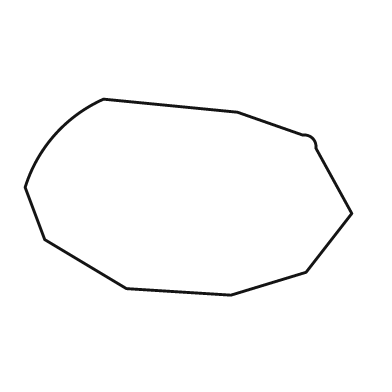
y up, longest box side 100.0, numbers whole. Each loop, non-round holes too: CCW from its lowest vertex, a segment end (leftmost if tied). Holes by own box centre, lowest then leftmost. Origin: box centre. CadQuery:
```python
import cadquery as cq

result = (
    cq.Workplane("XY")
    .moveTo(13.0, -30.0)
    .lineTo(36.0, -23.0)
    .lineTo(50.0, -5.0)
    .lineTo(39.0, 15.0)
    .threePointArc((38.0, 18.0), (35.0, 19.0))
    .lineTo(15.0, 26.0)
    .lineTo(-26.0, 30.0)
    .threePointArc((-41.0, 19.0), (-50.0, 3.0))
    .lineTo(-44.0, -13.0)
    .lineTo(-19.0, -28.0)
    .close()
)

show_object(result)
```